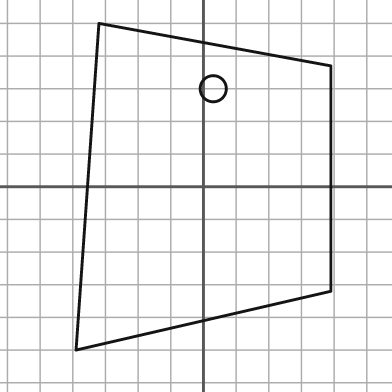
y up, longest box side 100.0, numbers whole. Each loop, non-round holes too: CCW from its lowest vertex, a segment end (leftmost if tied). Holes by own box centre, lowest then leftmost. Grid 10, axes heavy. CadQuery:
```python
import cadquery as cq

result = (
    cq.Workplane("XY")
    .moveTo(-39.0, -50.0)
    .lineTo(39.0, -32.0)
    .lineTo(39.0, 37.0)
    .lineTo(-32.0, 50.0)
    .close()
    .moveTo(3.0, 30.0)
    .circle(4.0)
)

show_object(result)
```